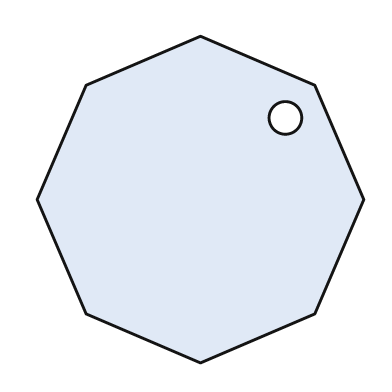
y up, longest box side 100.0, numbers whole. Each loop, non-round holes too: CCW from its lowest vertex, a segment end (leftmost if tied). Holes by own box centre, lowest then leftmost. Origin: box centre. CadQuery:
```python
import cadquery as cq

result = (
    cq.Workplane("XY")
    .moveTo(0.0, -50.0)
    .lineTo(35.0, -35.0)
    .lineTo(50.0, 0.0)
    .lineTo(35.0, 35.0)
    .lineTo(0.0, 50.0)
    .lineTo(-35.0, 35.0)
    .lineTo(-50.0, 0.0)
    .lineTo(-35.0, -35.0)
    .close()
    .moveTo(26.0, 25.0)
    .circle(5.0)
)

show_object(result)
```